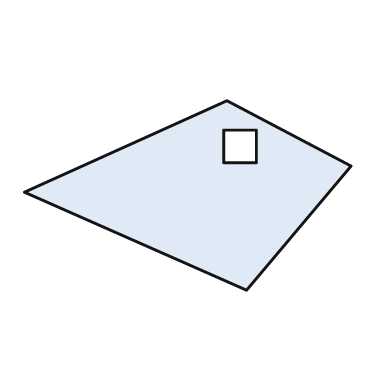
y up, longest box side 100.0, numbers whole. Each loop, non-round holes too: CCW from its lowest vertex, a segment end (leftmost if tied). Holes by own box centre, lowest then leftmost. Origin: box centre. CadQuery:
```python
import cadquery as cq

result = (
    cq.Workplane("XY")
    .moveTo(18.0, -29.0)
    .lineTo(50.0, 9.0)
    .lineTo(12.0, 29.0)
    .lineTo(-50.0, 1.0)
    .close()
    .moveTo(11.0, 10.0)
    .lineTo(21.0, 10.0)
    .lineTo(21.0, 20.0)
    .lineTo(11.0, 20.0)
    .close()
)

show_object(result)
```